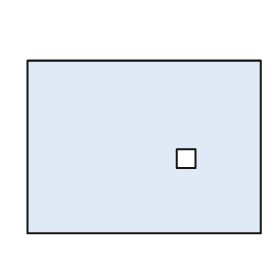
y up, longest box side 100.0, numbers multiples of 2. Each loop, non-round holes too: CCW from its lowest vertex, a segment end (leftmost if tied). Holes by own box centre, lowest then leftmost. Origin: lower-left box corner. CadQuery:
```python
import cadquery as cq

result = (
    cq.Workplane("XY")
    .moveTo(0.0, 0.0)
    .lineTo(100.0, 0.0)
    .lineTo(100.0, 74.0)
    .lineTo(0.0, 74.0)
    .close()
    .moveTo(64.0, 28.0)
    .lineTo(72.0, 28.0)
    .lineTo(72.0, 36.0)
    .lineTo(64.0, 36.0)
    .close()
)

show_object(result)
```